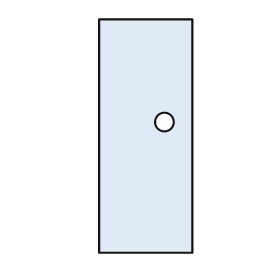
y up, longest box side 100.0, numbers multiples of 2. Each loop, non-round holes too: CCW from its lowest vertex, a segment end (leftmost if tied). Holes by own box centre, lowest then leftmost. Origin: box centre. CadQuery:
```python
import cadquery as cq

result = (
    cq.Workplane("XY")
    .moveTo(-20.0, -50.0)
    .lineTo(20.0, -50.0)
    .lineTo(20.0, 50.0)
    .lineTo(-20.0, 50.0)
    .close()
    .moveTo(8.0, 6.0)
    .circle(4.0)
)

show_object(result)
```